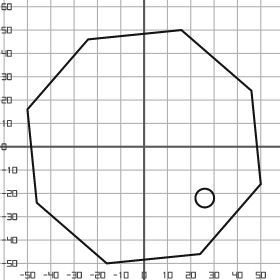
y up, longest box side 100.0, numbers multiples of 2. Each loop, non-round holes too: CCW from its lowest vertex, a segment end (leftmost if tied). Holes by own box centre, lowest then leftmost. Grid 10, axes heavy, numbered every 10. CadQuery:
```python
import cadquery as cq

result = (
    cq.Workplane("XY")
    .moveTo(-16.0, -50.0)
    .lineTo(24.0, -46.0)
    .lineTo(50.0, -16.0)
    .lineTo(46.0, 24.0)
    .lineTo(16.0, 50.0)
    .lineTo(-24.0, 46.0)
    .lineTo(-50.0, 16.0)
    .lineTo(-46.0, -24.0)
    .close()
    .moveTo(26.0, -22.0)
    .circle(4.0)
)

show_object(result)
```